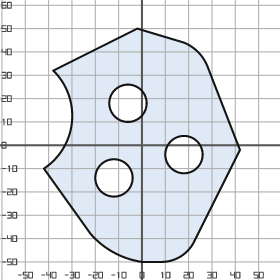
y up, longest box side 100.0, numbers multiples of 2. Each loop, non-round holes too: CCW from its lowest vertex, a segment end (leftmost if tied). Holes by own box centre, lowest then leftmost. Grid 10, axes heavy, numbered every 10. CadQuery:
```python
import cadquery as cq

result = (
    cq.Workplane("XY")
    .moveTo(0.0, -50.0)
    .lineTo(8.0, -50.0)
    .threePointArc((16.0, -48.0), (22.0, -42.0))
    .lineTo(42.0, -2.0)
    .lineTo(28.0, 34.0)
    .threePointArc((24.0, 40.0), (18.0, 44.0))
    .lineTo(-2.0, 50.0)
    .lineTo(-38.0, 32.0)
    .threePointArc((-30.0, 10.0), (-42.0, -10.0))
    .lineTo(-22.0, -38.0)
    .threePointArc((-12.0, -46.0), (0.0, -50.0))
    .close()
    .moveTo(-12.0, -14.0)
    .circle(8.0)
    .moveTo(18.0, -4.0)
    .circle(8.0)
    .moveTo(-6.0, 18.0)
    .circle(8.0)
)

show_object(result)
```